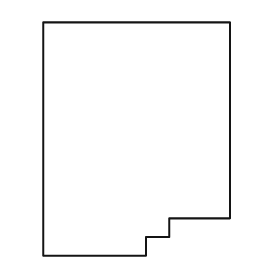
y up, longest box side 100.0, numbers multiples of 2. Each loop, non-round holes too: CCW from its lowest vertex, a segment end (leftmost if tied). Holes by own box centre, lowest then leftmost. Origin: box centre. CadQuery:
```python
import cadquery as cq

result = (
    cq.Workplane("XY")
    .moveTo(-40.0, -50.0)
    .lineTo(4.0, -50.0)
    .lineTo(4.0, -42.0)
    .lineTo(14.0, -42.0)
    .lineTo(14.0, -34.0)
    .lineTo(40.0, -34.0)
    .lineTo(40.0, 50.0)
    .lineTo(-40.0, 50.0)
    .close()
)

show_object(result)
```